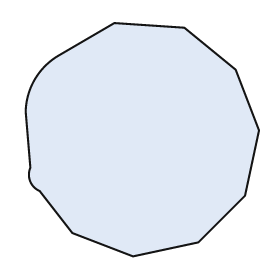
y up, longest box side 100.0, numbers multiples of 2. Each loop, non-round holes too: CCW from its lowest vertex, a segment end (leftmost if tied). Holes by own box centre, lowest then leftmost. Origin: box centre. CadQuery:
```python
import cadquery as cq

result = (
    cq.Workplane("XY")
    .moveTo(-4.0, -50.0)
    .lineTo(24.0, -44.0)
    .lineTo(44.0, -24.0)
    .lineTo(50.0, 4.0)
    .lineTo(40.0, 30.0)
    .lineTo(18.0, 48.0)
    .lineTo(-12.0, 50.0)
    .lineTo(-36.0, 36.0)
    .threePointArc((-46.0, 26.0), (-50.0, 12.0))
    .lineTo(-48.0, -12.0)
    .threePointArc((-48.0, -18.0), (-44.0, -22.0))
    .lineTo(-30.0, -40.0)
    .close()
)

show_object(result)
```